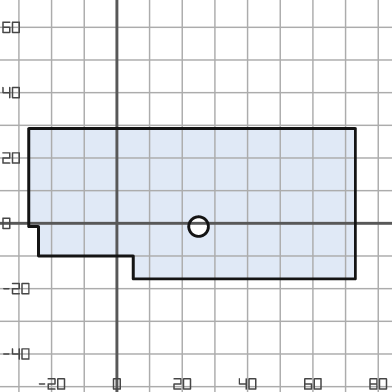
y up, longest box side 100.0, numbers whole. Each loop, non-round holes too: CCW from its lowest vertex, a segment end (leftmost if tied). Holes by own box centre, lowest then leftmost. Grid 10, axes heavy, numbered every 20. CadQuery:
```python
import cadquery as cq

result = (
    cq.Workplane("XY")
    .moveTo(5.0, -17.0)
    .lineTo(73.0, -17.0)
    .lineTo(73.0, 29.0)
    .lineTo(-27.0, 29.0)
    .lineTo(-27.0, -1.0)
    .lineTo(-24.0, -1.0)
    .lineTo(-24.0, -10.0)
    .lineTo(5.0, -10.0)
    .close()
    .moveTo(25.0, -1.0)
    .circle(3.0)
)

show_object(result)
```